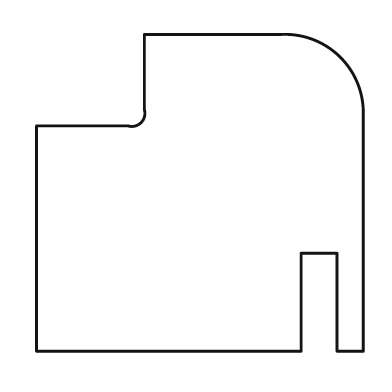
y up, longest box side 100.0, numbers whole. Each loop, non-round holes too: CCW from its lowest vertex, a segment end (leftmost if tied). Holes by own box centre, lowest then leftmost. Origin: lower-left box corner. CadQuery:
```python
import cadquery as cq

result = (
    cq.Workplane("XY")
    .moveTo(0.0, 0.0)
    .lineTo(81.0, 0.0)
    .lineTo(81.0, 30.0)
    .lineTo(92.0, 30.0)
    .lineTo(92.0, 0.0)
    .lineTo(100.0, 0.0)
    .lineTo(100.0, 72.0)
    .threePointArc((93.0, 90.0), (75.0, 97.0))
    .lineTo(33.0, 97.0)
    .lineTo(33.0, 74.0)
    .threePointArc((32.0, 70.0), (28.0, 69.0))
    .lineTo(0.0, 69.0)
    .close()
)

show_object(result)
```